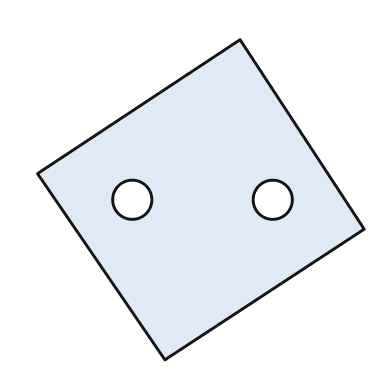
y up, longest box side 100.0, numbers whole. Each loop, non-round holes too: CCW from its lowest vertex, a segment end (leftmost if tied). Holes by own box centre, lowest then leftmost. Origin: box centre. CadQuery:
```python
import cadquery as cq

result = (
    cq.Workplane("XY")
    .moveTo(-11.0, -49.0)
    .lineTo(50.0, -9.0)
    .lineTo(12.0, 49.0)
    .lineTo(-50.0, 8.0)
    .close()
    .moveTo(-21.0, 0.0)
    .circle(6.0)
    .moveTo(22.0, 0.0)
    .circle(6.0)
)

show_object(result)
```